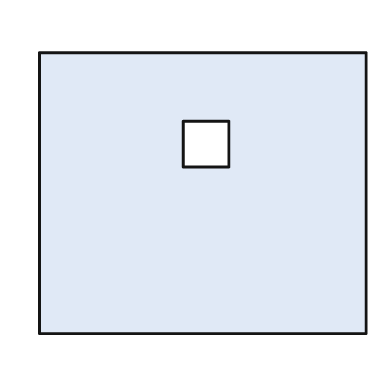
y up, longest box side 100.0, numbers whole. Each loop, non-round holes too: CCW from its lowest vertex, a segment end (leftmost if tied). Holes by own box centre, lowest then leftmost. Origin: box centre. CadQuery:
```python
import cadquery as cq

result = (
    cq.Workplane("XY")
    .moveTo(-50.0, -43.0)
    .lineTo(50.0, -43.0)
    .lineTo(50.0, 43.0)
    .lineTo(-50.0, 43.0)
    .close()
    .moveTo(-6.0, 8.0)
    .lineTo(8.0, 8.0)
    .lineTo(8.0, 22.0)
    .lineTo(-6.0, 22.0)
    .close()
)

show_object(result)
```